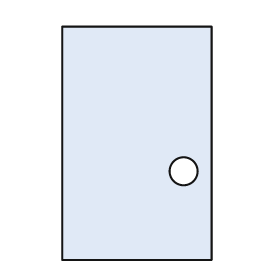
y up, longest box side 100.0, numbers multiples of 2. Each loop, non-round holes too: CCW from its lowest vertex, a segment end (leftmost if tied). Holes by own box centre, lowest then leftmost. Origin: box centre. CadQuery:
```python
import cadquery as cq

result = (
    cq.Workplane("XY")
    .moveTo(-32.0, -50.0)
    .lineTo(32.0, -50.0)
    .lineTo(32.0, 50.0)
    .lineTo(-32.0, 50.0)
    .close()
    .moveTo(20.0, -12.0)
    .circle(6.0)
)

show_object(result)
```